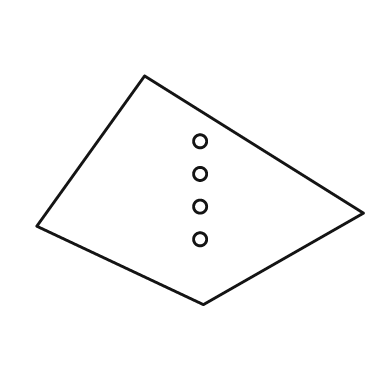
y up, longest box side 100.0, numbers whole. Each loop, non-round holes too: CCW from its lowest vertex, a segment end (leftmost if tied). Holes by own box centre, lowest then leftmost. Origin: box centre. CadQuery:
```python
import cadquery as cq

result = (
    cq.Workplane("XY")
    .moveTo(1.0, -35.0)
    .lineTo(50.0, -7.0)
    .lineTo(-17.0, 35.0)
    .lineTo(-50.0, -11.0)
    .close()
    .moveTo(0.0, -15.0)
    .circle(2.0)
    .moveTo(0.0, -5.0)
    .circle(2.0)
    .moveTo(0.0, 5.0)
    .circle(2.0)
    .moveTo(0.0, 15.0)
    .circle(2.0)
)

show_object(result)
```